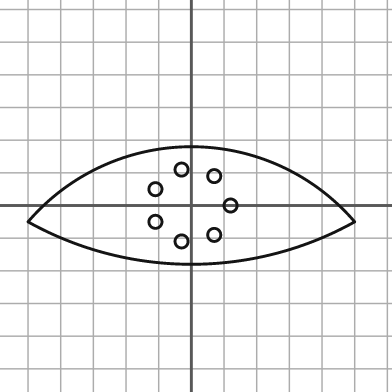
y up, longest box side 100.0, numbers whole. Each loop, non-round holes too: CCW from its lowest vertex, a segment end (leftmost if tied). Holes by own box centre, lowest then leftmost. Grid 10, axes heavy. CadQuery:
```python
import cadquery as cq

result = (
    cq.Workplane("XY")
    .moveTo(-50.0, -5.0)
    .threePointArc((0.0, -18.0), (50.0, -5.0))
    .threePointArc((0.0, 18.0), (-50.0, -5.0))
    .close()
    .moveTo(-3.0, -11.0)
    .circle(2.0)
    .moveTo(7.0, -9.0)
    .circle(2.0)
    .moveTo(-11.0, -5.0)
    .circle(2.0)
    .moveTo(12.0, 0.0)
    .circle(2.0)
    .moveTo(-11.0, 5.0)
    .circle(2.0)
    .moveTo(7.0, 9.0)
    .circle(2.0)
    .moveTo(-3.0, 11.0)
    .circle(2.0)
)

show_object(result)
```